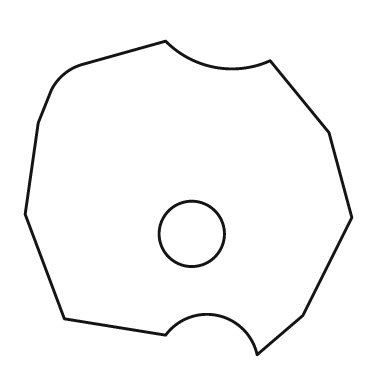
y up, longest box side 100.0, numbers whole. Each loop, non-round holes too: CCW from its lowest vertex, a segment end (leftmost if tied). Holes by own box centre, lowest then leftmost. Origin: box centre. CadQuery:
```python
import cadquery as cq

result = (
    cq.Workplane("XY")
    .moveTo(21.0, -48.0)
    .lineTo(35.0, -36.0)
    .lineTo(50.0, -6.0)
    .lineTo(43.0, 20.0)
    .lineTo(25.0, 42.0)
    .threePointArc((8.0, 40.0), (-7.0, 48.0))
    .lineTo(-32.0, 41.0)
    .threePointArc((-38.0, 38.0), (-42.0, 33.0))
    .lineTo(-46.0, 23.0)
    .lineTo(-50.0, -5.0)
    .lineTo(-38.0, -37.0)
    .lineTo(-7.0, -42.0)
    .threePointArc((9.0, -36.0), (21.0, -48.0))
    .close()
    .moveTo(1.0, -11.0)
    .circle(10.0)
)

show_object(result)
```